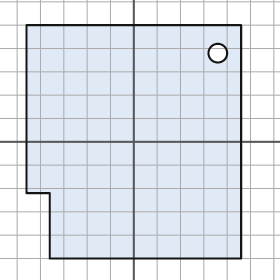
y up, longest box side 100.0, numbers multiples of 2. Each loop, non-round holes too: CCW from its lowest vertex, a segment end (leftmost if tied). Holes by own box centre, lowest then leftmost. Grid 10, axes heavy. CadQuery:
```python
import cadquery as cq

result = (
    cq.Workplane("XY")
    .moveTo(-36.0, -50.0)
    .lineTo(46.0, -50.0)
    .lineTo(46.0, 50.0)
    .lineTo(-46.0, 50.0)
    .lineTo(-46.0, -22.0)
    .lineTo(-36.0, -22.0)
    .close()
    .moveTo(36.0, 38.0)
    .circle(4.0)
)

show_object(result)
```